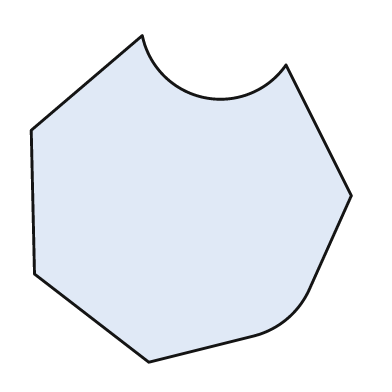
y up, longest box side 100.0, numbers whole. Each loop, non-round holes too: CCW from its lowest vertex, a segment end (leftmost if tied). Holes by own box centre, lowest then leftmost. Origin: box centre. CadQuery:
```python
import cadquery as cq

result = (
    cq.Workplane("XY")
    .moveTo(-13.0, -50.0)
    .lineTo(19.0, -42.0)
    .threePointArc((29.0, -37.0), (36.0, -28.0))
    .lineTo(49.0, 1.0)
    .lineTo(29.0, 41.0)
    .threePointArc((4.0, 31.0), (-15.0, 50.0))
    .lineTo(-49.0, 21.0)
    .lineTo(-48.0, -23.0)
    .close()
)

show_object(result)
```